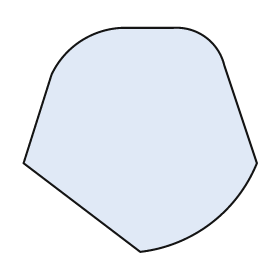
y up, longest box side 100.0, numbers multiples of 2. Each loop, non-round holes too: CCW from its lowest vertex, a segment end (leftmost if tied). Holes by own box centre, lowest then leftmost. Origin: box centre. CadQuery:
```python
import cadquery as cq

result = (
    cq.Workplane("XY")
    .moveTo(0.0, -48.0)
    .threePointArc((30.0, -36.0), (50.0, -10.0))
    .lineTo(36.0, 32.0)
    .threePointArc((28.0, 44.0), (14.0, 48.0))
    .lineTo(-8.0, 48.0)
    .threePointArc((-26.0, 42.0), (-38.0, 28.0))
    .lineTo(-50.0, -10.0)
    .close()
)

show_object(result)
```